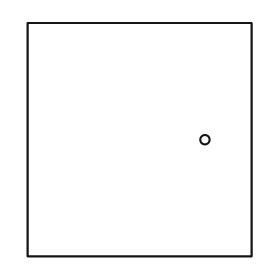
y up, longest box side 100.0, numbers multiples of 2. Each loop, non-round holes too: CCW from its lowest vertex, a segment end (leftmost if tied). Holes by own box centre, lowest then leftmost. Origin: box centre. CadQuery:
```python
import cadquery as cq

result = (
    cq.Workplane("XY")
    .moveTo(-48.0, -50.0)
    .lineTo(48.0, -50.0)
    .lineTo(48.0, 50.0)
    .lineTo(-48.0, 50.0)
    .close()
    .moveTo(28.0, 0.0)
    .circle(2.0)
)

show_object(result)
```